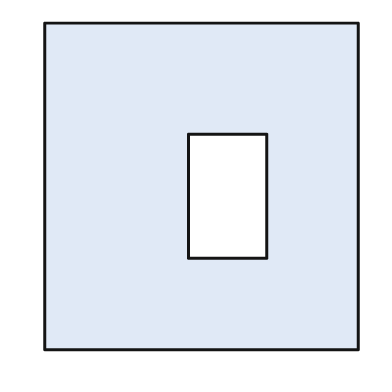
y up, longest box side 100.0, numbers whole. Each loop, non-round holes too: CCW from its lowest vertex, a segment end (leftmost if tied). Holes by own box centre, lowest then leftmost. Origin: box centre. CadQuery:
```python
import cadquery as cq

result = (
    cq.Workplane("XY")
    .moveTo(-48.0, -50.0)
    .lineTo(48.0, -50.0)
    .lineTo(48.0, 50.0)
    .lineTo(-48.0, 50.0)
    .close()
    .moveTo(-4.0, -22.0)
    .lineTo(20.0, -22.0)
    .lineTo(20.0, 16.0)
    .lineTo(-4.0, 16.0)
    .close()
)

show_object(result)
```